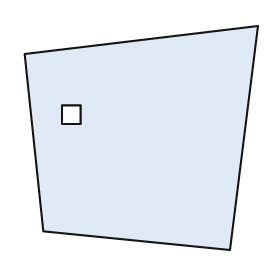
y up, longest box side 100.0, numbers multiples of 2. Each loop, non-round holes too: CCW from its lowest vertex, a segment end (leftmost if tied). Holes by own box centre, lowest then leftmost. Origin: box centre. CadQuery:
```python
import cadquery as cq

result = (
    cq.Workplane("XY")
    .moveTo(38.0, -48.0)
    .lineTo(50.0, 48.0)
    .lineTo(-50.0, 36.0)
    .lineTo(-42.0, -40.0)
    .close()
    .moveTo(-34.0, 6.0)
    .lineTo(-26.0, 6.0)
    .lineTo(-26.0, 14.0)
    .lineTo(-34.0, 14.0)
    .close()
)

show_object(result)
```